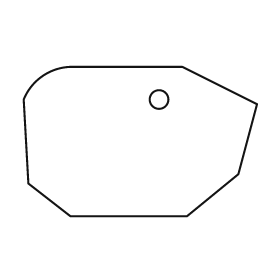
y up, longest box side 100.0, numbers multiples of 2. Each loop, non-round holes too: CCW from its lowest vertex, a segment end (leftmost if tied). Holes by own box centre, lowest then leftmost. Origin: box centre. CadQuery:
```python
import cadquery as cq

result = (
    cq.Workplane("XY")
    .moveTo(-30.0, -32.0)
    .lineTo(20.0, -32.0)
    .lineTo(42.0, -14.0)
    .lineTo(50.0, 16.0)
    .lineTo(18.0, 32.0)
    .lineTo(-30.0, 32.0)
    .threePointArc((-42.0, 28.0), (-50.0, 18.0))
    .lineTo(-48.0, -18.0)
    .close()
    .moveTo(8.0, 18.0)
    .circle(4.0)
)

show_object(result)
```